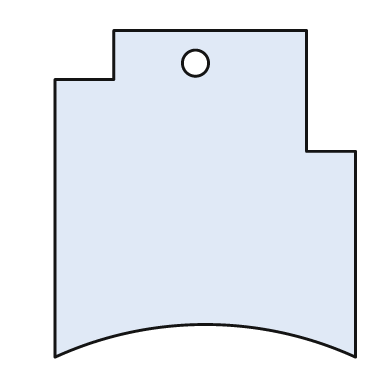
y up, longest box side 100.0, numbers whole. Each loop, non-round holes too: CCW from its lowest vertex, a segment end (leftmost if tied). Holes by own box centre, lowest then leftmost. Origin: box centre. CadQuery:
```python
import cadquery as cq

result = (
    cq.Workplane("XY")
    .moveTo(-46.0, -50.0)
    .threePointArc((0.0, -40.0), (46.0, -50.0))
    .lineTo(46.0, 13.0)
    .lineTo(31.0, 13.0)
    .lineTo(31.0, 50.0)
    .lineTo(-28.0, 50.0)
    .lineTo(-28.0, 35.0)
    .lineTo(-46.0, 35.0)
    .close()
    .moveTo(-3.0, 40.0)
    .circle(4.0)
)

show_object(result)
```